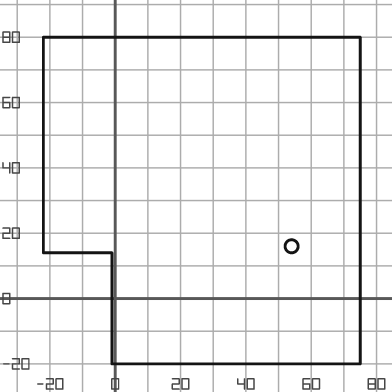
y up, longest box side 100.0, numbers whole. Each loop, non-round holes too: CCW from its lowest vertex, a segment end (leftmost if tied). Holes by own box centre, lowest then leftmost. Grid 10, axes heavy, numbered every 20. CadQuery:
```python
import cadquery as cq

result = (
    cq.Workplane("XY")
    .moveTo(-1.0, -20.0)
    .lineTo(75.0, -20.0)
    .lineTo(75.0, 80.0)
    .lineTo(-22.0, 80.0)
    .lineTo(-22.0, 14.0)
    .lineTo(-1.0, 14.0)
    .close()
    .moveTo(54.0, 16.0)
    .circle(2.0)
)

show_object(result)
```